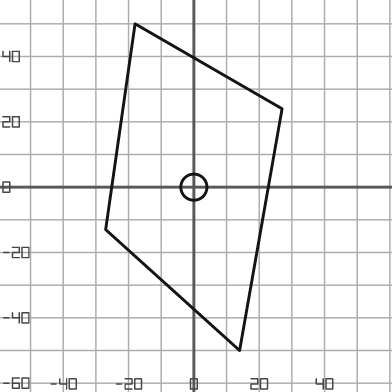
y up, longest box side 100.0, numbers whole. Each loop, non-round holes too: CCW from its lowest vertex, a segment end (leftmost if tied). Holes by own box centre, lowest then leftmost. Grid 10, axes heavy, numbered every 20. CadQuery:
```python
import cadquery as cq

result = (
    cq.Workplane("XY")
    .moveTo(14.0, -50.0)
    .lineTo(27.0, 24.0)
    .lineTo(-18.0, 50.0)
    .lineTo(-27.0, -13.0)
    .close()
    .moveTo(0.0, 0.0)
    .circle(4.0)
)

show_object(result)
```